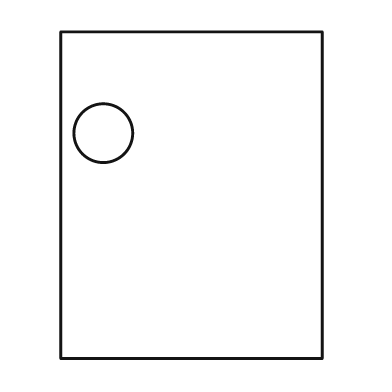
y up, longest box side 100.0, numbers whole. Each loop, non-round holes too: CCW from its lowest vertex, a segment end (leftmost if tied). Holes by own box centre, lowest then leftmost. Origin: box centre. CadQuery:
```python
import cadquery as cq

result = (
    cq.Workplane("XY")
    .moveTo(-40.0, -50.0)
    .lineTo(40.0, -50.0)
    .lineTo(40.0, 50.0)
    .lineTo(-40.0, 50.0)
    .close()
    .moveTo(-27.0, 19.0)
    .circle(9.0)
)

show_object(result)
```